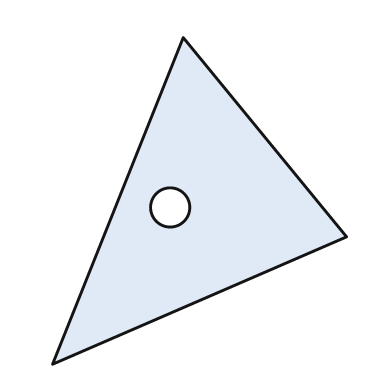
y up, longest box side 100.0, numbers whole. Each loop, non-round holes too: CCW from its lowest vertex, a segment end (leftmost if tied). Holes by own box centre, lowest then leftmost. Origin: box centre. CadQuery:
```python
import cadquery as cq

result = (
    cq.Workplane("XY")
    .moveTo(-45.0, -50.0)
    .lineTo(45.0, -11.0)
    .lineTo(-5.0, 50.0)
    .close()
    .moveTo(-9.0, -2.0)
    .circle(6.0)
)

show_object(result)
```